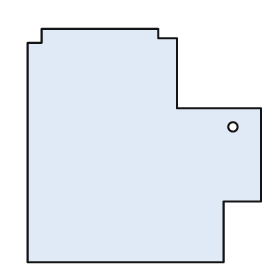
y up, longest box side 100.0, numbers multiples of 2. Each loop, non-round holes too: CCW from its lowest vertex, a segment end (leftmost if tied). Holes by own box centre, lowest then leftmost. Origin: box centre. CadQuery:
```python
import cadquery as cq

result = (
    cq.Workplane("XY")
    .moveTo(-50.0, -50.0)
    .lineTo(34.0, -50.0)
    .lineTo(34.0, -24.0)
    .lineTo(50.0, -24.0)
    .lineTo(50.0, 16.0)
    .lineTo(14.0, 16.0)
    .lineTo(14.0, 46.0)
    .lineTo(6.0, 46.0)
    .lineTo(6.0, 50.0)
    .lineTo(-44.0, 50.0)
    .lineTo(-44.0, 44.0)
    .lineTo(-50.0, 44.0)
    .close()
    .moveTo(38.0, 8.0)
    .circle(2.0)
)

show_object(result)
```